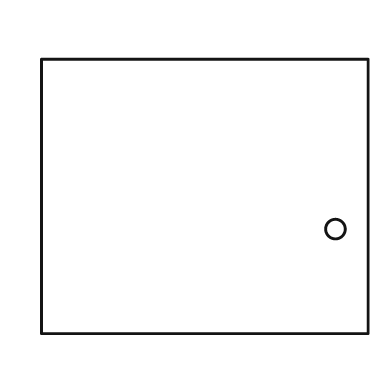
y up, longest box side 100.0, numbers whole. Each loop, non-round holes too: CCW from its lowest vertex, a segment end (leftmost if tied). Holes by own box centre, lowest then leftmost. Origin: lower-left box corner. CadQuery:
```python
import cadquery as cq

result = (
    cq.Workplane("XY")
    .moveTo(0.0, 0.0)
    .lineTo(100.0, 0.0)
    .lineTo(100.0, 84.0)
    .lineTo(0.0, 84.0)
    .close()
    .moveTo(90.0, 32.0)
    .circle(3.0)
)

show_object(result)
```